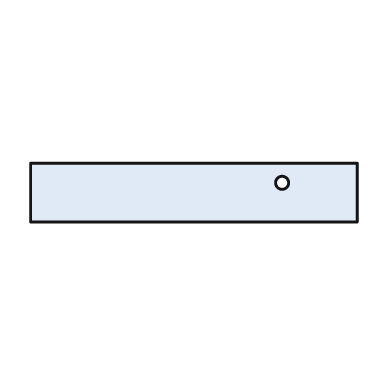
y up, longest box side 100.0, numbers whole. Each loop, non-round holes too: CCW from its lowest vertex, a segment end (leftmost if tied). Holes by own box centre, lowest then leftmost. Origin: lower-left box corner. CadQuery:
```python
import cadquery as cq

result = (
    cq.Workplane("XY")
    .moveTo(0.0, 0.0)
    .lineTo(100.0, 0.0)
    .lineTo(100.0, 18.0)
    .lineTo(0.0, 18.0)
    .close()
    .moveTo(77.0, 12.0)
    .circle(2.0)
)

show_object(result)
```